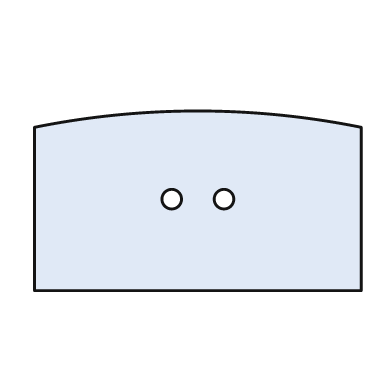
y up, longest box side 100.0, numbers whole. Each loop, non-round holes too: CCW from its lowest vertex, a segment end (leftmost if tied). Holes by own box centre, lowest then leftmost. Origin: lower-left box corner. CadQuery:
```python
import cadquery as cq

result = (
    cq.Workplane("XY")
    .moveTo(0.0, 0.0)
    .lineTo(100.0, 0.0)
    .lineTo(100.0, 50.0)
    .threePointArc((50.0, 55.0), (0.0, 50.0))
    .close()
    .moveTo(42.0, 28.0)
    .circle(3.0)
    .moveTo(58.0, 28.0)
    .circle(3.0)
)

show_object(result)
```